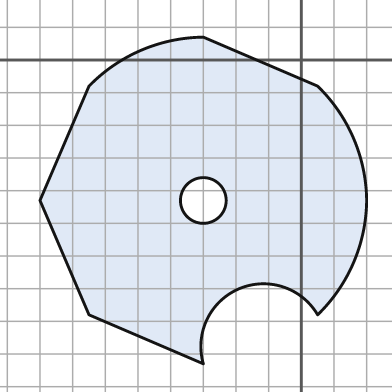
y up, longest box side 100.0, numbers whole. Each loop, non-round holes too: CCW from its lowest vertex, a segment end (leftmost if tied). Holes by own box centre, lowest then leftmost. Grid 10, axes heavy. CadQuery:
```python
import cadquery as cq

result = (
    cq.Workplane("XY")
    .moveTo(-30.0, -93.0)
    .threePointArc((-19.0, -70.0), (5.0, -78.0))
    .threePointArc((16.0, -62.0), (20.0, -43.0))
    .threePointArc((16.0, -24.0), (5.0, -8.0))
    .lineTo(-30.0, 7.0)
    .threePointArc((-49.0, 3.0), (-65.0, -8.0))
    .lineTo(-80.0, -43.0)
    .lineTo(-65.0, -78.0)
    .close()
    .moveTo(-30.0, -43.0)
    .circle(7.0)
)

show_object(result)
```